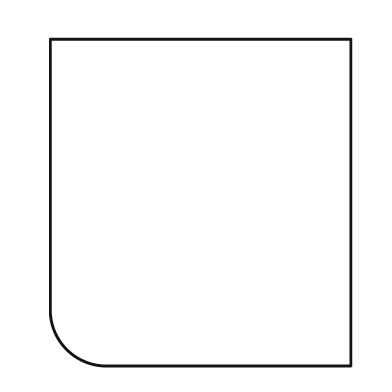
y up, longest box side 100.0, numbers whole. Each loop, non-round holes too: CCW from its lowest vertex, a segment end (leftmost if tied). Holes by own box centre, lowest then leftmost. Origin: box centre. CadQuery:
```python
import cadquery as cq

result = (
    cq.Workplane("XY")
    .moveTo(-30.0, -50.0)
    .lineTo(46.0, -50.0)
    .lineTo(46.0, 50.0)
    .lineTo(-46.0, 50.0)
    .lineTo(-46.0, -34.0)
    .threePointArc((-41.0, -45.0), (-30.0, -50.0))
    .close()
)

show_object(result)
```